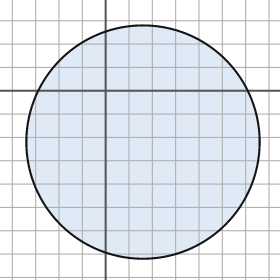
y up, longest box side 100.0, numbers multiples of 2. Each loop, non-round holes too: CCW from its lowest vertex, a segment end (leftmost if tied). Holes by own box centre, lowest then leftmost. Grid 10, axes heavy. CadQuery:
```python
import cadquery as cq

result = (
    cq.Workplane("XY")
    .moveTo(16.0, -22.0)
    .circle(50.0)
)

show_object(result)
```